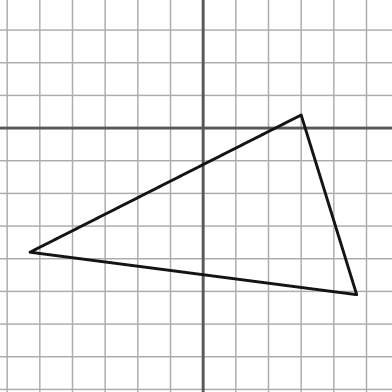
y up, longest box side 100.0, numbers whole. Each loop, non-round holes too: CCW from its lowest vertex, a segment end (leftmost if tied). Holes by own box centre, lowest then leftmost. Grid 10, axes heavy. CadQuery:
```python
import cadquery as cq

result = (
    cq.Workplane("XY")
    .moveTo(47.0, -51.0)
    .lineTo(30.0, 4.0)
    .lineTo(-53.0, -38.0)
    .close()
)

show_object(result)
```